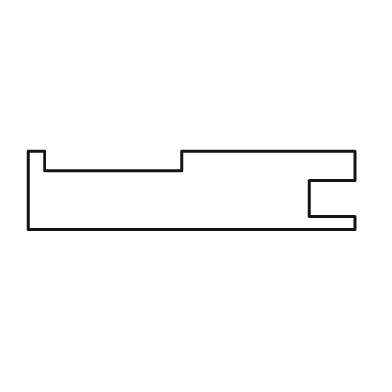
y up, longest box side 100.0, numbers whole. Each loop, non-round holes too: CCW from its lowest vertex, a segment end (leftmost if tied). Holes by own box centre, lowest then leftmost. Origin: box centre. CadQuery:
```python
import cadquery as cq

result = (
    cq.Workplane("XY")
    .moveTo(-50.0, -12.0)
    .lineTo(50.0, -12.0)
    .lineTo(50.0, -8.0)
    .lineTo(36.0, -8.0)
    .lineTo(36.0, 3.0)
    .lineTo(50.0, 3.0)
    .lineTo(50.0, 12.0)
    .lineTo(-3.0, 12.0)
    .lineTo(-3.0, 6.0)
    .lineTo(-45.0, 6.0)
    .lineTo(-45.0, 12.0)
    .lineTo(-50.0, 12.0)
    .close()
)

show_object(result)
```